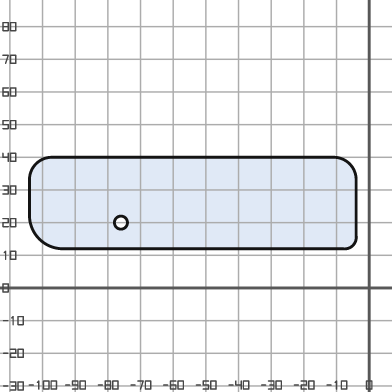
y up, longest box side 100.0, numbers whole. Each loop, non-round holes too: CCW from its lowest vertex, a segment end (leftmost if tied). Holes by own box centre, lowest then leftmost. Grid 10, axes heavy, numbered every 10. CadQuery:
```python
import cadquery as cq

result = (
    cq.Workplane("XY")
    .moveTo(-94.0, 12.0)
    .lineTo(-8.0, 12.0)
    .threePointArc((-5.0, 13.0), (-4.0, 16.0))
    .lineTo(-4.0, 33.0)
    .threePointArc((-6.0, 38.0), (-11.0, 40.0))
    .lineTo(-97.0, 40.0)
    .threePointArc((-102.0, 38.0), (-104.0, 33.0))
    .lineTo(-104.0, 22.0)
    .threePointArc((-101.0, 15.0), (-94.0, 12.0))
    .close()
    .moveTo(-76.0, 20.0)
    .circle(2.0)
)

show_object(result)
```